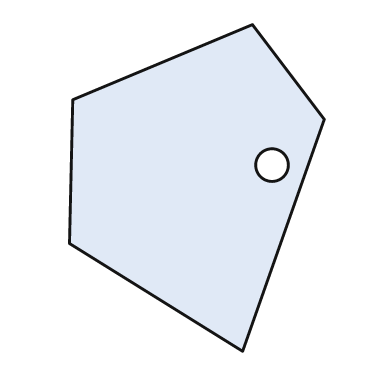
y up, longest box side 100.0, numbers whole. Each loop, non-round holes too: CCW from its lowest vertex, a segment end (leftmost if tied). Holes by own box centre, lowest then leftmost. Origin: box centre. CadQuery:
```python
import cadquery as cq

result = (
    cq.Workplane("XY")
    .moveTo(14.0, -50.0)
    .lineTo(39.0, 21.0)
    .lineTo(17.0, 50.0)
    .lineTo(-38.0, 27.0)
    .lineTo(-39.0, -17.0)
    .close()
    .moveTo(23.0, 7.0)
    .circle(5.0)
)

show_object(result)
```